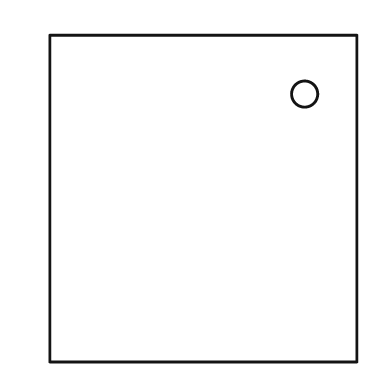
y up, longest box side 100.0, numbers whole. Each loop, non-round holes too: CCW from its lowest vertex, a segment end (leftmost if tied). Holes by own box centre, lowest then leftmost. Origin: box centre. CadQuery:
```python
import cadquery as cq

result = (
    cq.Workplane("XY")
    .moveTo(-47.0, -50.0)
    .lineTo(47.0, -50.0)
    .lineTo(47.0, 50.0)
    .lineTo(-47.0, 50.0)
    .close()
    .moveTo(31.0, 32.0)
    .circle(4.0)
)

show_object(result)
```